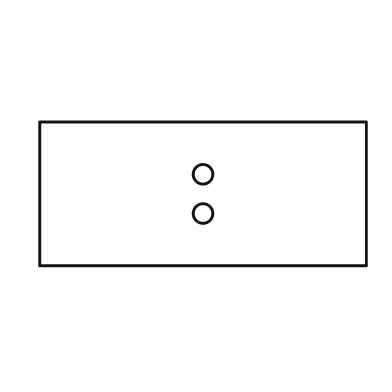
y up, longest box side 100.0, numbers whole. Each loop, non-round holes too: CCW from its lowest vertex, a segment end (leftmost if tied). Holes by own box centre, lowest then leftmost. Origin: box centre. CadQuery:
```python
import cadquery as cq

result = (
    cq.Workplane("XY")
    .moveTo(-50.0, -22.0)
    .lineTo(50.0, -22.0)
    .lineTo(50.0, 22.0)
    .lineTo(-50.0, 22.0)
    .close()
    .moveTo(0.0, -6.0)
    .circle(3.0)
    .moveTo(0.0, 6.0)
    .circle(3.0)
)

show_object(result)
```